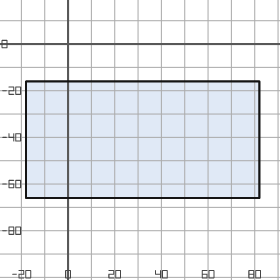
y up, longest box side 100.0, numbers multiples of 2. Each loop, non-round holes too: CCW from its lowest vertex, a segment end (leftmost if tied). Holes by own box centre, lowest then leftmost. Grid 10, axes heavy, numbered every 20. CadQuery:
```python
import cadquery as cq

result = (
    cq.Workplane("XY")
    .moveTo(-18.0, -66.0)
    .lineTo(82.0, -66.0)
    .lineTo(82.0, -16.0)
    .lineTo(-18.0, -16.0)
    .close()
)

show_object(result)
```